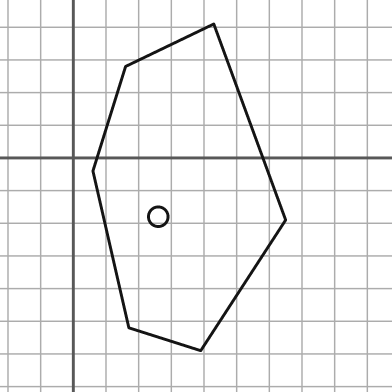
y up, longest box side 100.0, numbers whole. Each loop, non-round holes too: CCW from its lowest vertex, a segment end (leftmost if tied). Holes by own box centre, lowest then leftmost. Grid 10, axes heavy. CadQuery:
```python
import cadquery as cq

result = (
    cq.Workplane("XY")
    .moveTo(39.0, -59.0)
    .lineTo(65.0, -19.0)
    .lineTo(43.0, 41.0)
    .lineTo(16.0, 28.0)
    .lineTo(6.0, -4.0)
    .lineTo(17.0, -52.0)
    .close()
    .moveTo(26.0, -18.0)
    .circle(3.0)
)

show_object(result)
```